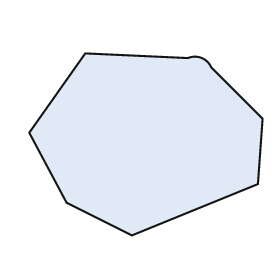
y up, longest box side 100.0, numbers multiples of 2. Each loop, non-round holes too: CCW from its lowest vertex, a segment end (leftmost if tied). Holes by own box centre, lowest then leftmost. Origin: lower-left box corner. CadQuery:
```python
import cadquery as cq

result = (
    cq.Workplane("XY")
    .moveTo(44.0, 0.0)
    .lineTo(98.0, 22.0)
    .lineTo(100.0, 50.0)
    .lineTo(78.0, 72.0)
    .threePointArc((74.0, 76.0), (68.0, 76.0))
    .lineTo(24.0, 78.0)
    .lineTo(0.0, 44.0)
    .lineTo(16.0, 14.0)
    .close()
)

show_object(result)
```